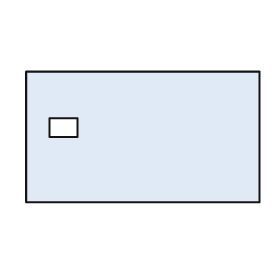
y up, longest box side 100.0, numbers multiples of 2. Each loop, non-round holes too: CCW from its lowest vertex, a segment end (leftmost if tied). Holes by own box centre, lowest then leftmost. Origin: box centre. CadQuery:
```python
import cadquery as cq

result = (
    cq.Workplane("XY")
    .moveTo(-50.0, -28.0)
    .lineTo(50.0, -28.0)
    .lineTo(50.0, 28.0)
    .lineTo(-50.0, 28.0)
    .close()
    .moveTo(-40.0, 0.0)
    .lineTo(-28.0, 0.0)
    .lineTo(-28.0, 8.0)
    .lineTo(-40.0, 8.0)
    .close()
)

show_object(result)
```